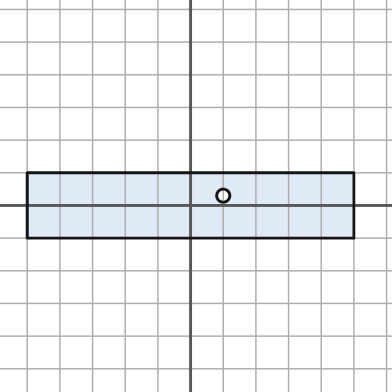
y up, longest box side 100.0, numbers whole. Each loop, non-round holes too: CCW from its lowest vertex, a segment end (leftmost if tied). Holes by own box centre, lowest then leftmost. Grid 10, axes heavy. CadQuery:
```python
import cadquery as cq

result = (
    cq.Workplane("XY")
    .moveTo(-50.0, -10.0)
    .lineTo(50.0, -10.0)
    .lineTo(50.0, 10.0)
    .lineTo(-50.0, 10.0)
    .close()
    .moveTo(10.0, 3.0)
    .circle(2.0)
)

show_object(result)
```